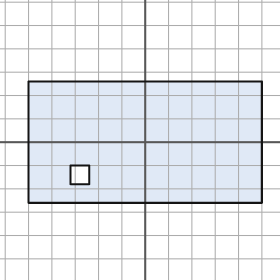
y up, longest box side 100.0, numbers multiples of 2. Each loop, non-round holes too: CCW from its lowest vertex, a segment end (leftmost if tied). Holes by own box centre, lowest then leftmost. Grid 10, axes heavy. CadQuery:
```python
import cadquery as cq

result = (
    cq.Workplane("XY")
    .moveTo(-50.0, -26.0)
    .lineTo(50.0, -26.0)
    .lineTo(50.0, 26.0)
    .lineTo(-50.0, 26.0)
    .close()
    .moveTo(-32.0, -18.0)
    .lineTo(-24.0, -18.0)
    .lineTo(-24.0, -10.0)
    .lineTo(-32.0, -10.0)
    .close()
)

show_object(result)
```